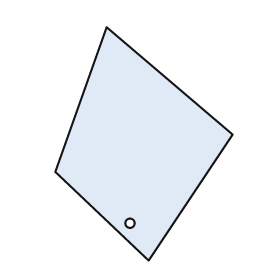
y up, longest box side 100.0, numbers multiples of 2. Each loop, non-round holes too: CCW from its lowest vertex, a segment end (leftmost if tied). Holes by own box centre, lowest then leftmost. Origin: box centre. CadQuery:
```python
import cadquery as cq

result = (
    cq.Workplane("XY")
    .moveTo(2.0, -50.0)
    .lineTo(38.0, 4.0)
    .lineTo(-16.0, 50.0)
    .lineTo(-38.0, -12.0)
    .close()
    .moveTo(-6.0, -34.0)
    .circle(2.0)
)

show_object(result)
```